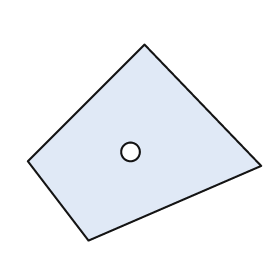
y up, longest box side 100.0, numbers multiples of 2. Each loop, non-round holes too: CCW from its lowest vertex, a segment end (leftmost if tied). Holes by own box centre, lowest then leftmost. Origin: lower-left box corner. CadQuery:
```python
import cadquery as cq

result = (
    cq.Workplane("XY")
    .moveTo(26.0, 0.0)
    .lineTo(100.0, 32.0)
    .lineTo(50.0, 84.0)
    .lineTo(0.0, 34.0)
    .close()
    .moveTo(44.0, 38.0)
    .circle(4.0)
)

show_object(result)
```